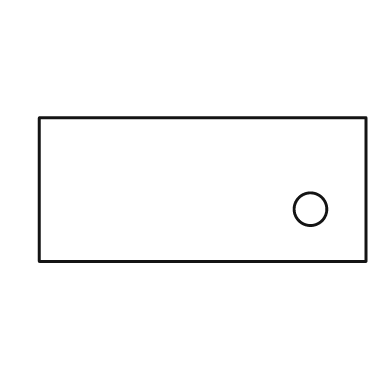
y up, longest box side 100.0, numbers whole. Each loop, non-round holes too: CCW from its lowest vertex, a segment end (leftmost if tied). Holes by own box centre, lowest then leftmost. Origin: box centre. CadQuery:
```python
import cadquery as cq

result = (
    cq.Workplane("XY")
    .moveTo(-50.0, -22.0)
    .lineTo(50.0, -22.0)
    .lineTo(50.0, 22.0)
    .lineTo(-50.0, 22.0)
    .close()
    .moveTo(33.0, -6.0)
    .circle(5.0)
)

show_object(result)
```